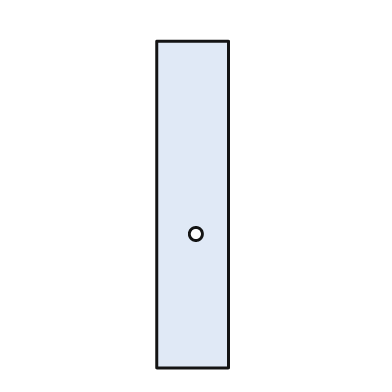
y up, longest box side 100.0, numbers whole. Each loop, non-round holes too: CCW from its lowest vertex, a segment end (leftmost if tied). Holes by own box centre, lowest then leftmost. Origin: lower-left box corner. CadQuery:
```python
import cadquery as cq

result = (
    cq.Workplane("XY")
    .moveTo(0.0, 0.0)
    .lineTo(22.0, 0.0)
    .lineTo(22.0, 100.0)
    .lineTo(0.0, 100.0)
    .close()
    .moveTo(12.0, 41.0)
    .circle(2.0)
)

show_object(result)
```